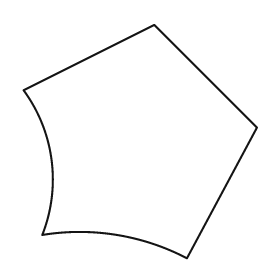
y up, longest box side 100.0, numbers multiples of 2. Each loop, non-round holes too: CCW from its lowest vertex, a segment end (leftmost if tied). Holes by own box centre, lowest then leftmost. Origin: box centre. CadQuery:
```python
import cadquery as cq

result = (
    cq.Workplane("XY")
    .moveTo(20.0, -50.0)
    .lineTo(50.0, 6.0)
    .lineTo(6.0, 50.0)
    .lineTo(-50.0, 22.0)
    .threePointArc((-38.0, -8.0), (-42.0, -40.0))
    .threePointArc((-10.0, -40.0), (20.0, -50.0))
    .close()
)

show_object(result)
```